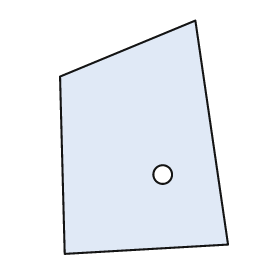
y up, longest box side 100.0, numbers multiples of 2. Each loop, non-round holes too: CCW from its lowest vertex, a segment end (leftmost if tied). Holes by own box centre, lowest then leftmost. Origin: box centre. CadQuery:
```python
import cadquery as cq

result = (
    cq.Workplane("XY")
    .moveTo(-34.0, -50.0)
    .lineTo(36.0, -46.0)
    .lineTo(22.0, 50.0)
    .lineTo(-36.0, 26.0)
    .close()
    .moveTo(8.0, -16.0)
    .circle(4.0)
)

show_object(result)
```